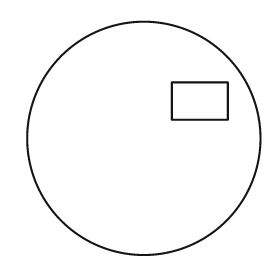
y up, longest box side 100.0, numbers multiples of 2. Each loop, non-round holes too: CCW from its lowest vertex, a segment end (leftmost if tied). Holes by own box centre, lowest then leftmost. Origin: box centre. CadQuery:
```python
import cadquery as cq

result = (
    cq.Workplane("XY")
    .moveTo(0.0, 0.0)
    .circle(50.0)
    .moveTo(12.0, 8.0)
    .lineTo(36.0, 8.0)
    .lineTo(36.0, 24.0)
    .lineTo(12.0, 24.0)
    .close()
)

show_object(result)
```